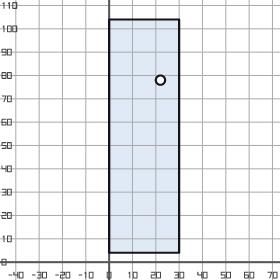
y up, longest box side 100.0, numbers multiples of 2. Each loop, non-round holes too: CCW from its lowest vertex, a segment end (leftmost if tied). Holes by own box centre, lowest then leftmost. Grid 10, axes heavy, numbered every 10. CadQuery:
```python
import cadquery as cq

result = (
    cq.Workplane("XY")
    .moveTo(0.0, 4.0)
    .lineTo(30.0, 4.0)
    .lineTo(30.0, 104.0)
    .lineTo(0.0, 104.0)
    .close()
    .moveTo(22.0, 78.0)
    .circle(2.0)
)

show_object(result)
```